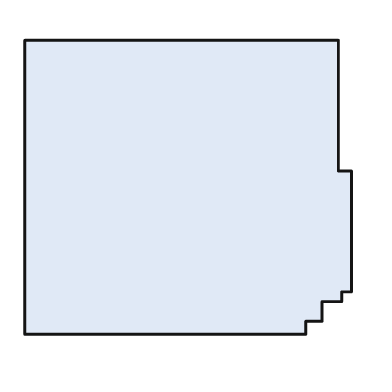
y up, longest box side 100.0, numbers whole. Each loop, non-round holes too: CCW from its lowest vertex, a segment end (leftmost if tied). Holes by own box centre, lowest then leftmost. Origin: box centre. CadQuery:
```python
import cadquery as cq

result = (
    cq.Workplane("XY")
    .moveTo(-50.0, -45.0)
    .lineTo(36.0, -45.0)
    .lineTo(36.0, -41.0)
    .lineTo(41.0, -41.0)
    .lineTo(41.0, -35.0)
    .lineTo(47.0, -35.0)
    .lineTo(47.0, -32.0)
    .lineTo(50.0, -32.0)
    .lineTo(50.0, 5.0)
    .lineTo(46.0, 5.0)
    .lineTo(46.0, 45.0)
    .lineTo(-50.0, 45.0)
    .close()
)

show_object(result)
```